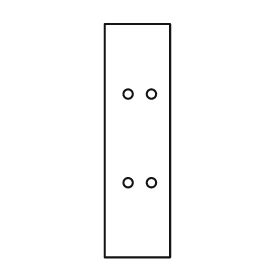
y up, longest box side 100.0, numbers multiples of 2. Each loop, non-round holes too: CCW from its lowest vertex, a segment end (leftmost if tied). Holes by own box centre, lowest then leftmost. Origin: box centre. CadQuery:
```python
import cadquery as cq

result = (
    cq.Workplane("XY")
    .moveTo(-14.0, -50.0)
    .lineTo(14.0, -50.0)
    .lineTo(14.0, 50.0)
    .lineTo(-14.0, 50.0)
    .close()
    .moveTo(-4.0, -18.0)
    .circle(2.0)
    .moveTo(6.0, -18.0)
    .circle(2.0)
    .moveTo(-4.0, 20.0)
    .circle(2.0)
    .moveTo(6.0, 20.0)
    .circle(2.0)
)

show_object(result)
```